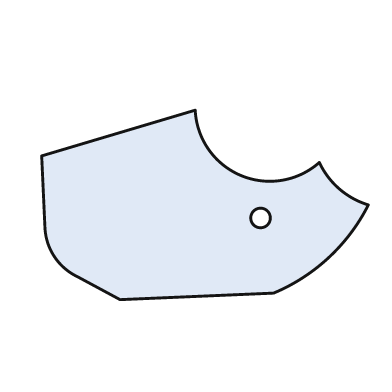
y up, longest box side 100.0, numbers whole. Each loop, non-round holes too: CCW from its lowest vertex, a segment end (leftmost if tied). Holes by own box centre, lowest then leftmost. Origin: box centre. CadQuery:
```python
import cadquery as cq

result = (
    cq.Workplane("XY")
    .moveTo(-26.0, -29.0)
    .lineTo(21.0, -27.0)
    .threePointArc((38.0, -16.0), (50.0, 0.0))
    .threePointArc((41.0, 5.0), (35.0, 13.0))
    .threePointArc((11.0, 9.0), (-3.0, 29.0))
    .lineTo(-50.0, 15.0)
    .lineTo(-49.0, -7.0)
    .threePointArc((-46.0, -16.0), (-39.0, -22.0))
    .close()
    .moveTo(17.0, -4.0)
    .circle(3.0)
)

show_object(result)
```